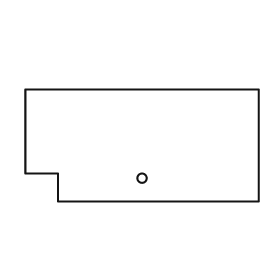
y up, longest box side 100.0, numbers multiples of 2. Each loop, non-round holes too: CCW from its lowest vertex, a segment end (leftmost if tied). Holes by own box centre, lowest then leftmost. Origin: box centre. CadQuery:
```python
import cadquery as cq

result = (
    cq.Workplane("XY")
    .moveTo(-36.0, -24.0)
    .lineTo(50.0, -24.0)
    .lineTo(50.0, 24.0)
    .lineTo(-50.0, 24.0)
    .lineTo(-50.0, -12.0)
    .lineTo(-36.0, -12.0)
    .close()
    .moveTo(0.0, -14.0)
    .circle(2.0)
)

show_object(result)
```